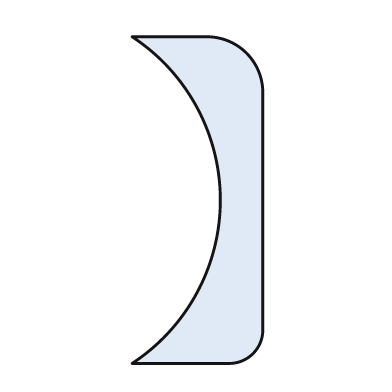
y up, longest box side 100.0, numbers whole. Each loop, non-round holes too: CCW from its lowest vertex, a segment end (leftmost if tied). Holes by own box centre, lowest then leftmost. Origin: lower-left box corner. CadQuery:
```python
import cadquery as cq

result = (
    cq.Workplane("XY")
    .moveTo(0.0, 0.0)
    .lineTo(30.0, 0.0)
    .threePointArc((37.0, 3.0), (40.0, 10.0))
    .lineTo(40.0, 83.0)
    .threePointArc((35.0, 95.0), (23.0, 100.0))
    .lineTo(0.0, 100.0)
    .threePointArc((27.0, 50.0), (0.0, 0.0))
    .close()
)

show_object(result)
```